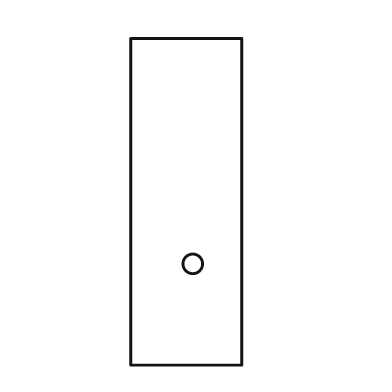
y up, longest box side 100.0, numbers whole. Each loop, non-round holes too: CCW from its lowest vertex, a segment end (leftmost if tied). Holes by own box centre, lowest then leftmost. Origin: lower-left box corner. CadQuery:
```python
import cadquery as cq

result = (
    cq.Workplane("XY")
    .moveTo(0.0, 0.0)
    .lineTo(34.0, 0.0)
    .lineTo(34.0, 100.0)
    .lineTo(0.0, 100.0)
    .close()
    .moveTo(19.0, 31.0)
    .circle(3.0)
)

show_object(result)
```